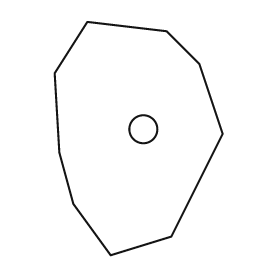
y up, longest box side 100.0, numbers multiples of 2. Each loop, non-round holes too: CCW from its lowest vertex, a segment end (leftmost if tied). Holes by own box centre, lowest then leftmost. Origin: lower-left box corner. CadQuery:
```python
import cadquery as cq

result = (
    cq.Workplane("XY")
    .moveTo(24.0, 0.0)
    .lineTo(50.0, 8.0)
    .lineTo(72.0, 52.0)
    .lineTo(62.0, 82.0)
    .lineTo(48.0, 96.0)
    .lineTo(14.0, 100.0)
    .lineTo(0.0, 78.0)
    .lineTo(2.0, 44.0)
    .lineTo(8.0, 22.0)
    .close()
    .moveTo(38.0, 54.0)
    .circle(6.0)
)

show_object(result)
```